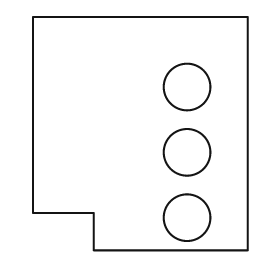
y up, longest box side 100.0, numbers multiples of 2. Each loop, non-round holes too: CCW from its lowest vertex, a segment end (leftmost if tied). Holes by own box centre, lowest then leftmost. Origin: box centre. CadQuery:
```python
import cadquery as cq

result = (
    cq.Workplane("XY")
    .moveTo(-20.0, -50.0)
    .lineTo(46.0, -50.0)
    .lineTo(46.0, 50.0)
    .lineTo(-46.0, 50.0)
    .lineTo(-46.0, -34.0)
    .lineTo(-20.0, -34.0)
    .close()
    .moveTo(20.0, -36.0)
    .circle(10.0)
    .moveTo(20.0, -8.0)
    .circle(10.0)
    .moveTo(20.0, 20.0)
    .circle(10.0)
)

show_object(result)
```